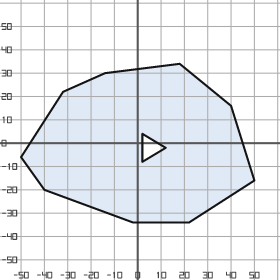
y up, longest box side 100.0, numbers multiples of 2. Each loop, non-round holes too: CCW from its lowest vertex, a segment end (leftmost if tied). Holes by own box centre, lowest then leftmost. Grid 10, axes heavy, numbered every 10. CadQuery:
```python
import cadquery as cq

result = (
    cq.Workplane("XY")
    .moveTo(-2.0, -34.0)
    .lineTo(22.0, -34.0)
    .lineTo(50.0, -16.0)
    .lineTo(40.0, 16.0)
    .lineTo(18.0, 34.0)
    .lineTo(-14.0, 30.0)
    .lineTo(-32.0, 22.0)
    .lineTo(-50.0, -6.0)
    .lineTo(-40.0, -20.0)
    .close()
    .moveTo(2.0, -8.0)
    .lineTo(12.0, -2.0)
    .lineTo(2.0, 4.0)
    .close()
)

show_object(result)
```